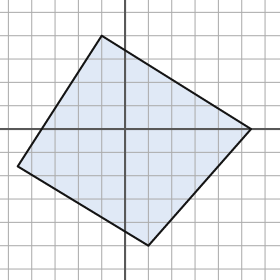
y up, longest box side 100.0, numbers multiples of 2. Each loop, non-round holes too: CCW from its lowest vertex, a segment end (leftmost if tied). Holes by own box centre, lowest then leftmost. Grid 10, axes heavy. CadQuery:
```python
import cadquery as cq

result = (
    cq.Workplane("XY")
    .moveTo(10.0, -50.0)
    .lineTo(54.0, 0.0)
    .lineTo(-10.0, 40.0)
    .lineTo(-46.0, -16.0)
    .close()
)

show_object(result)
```